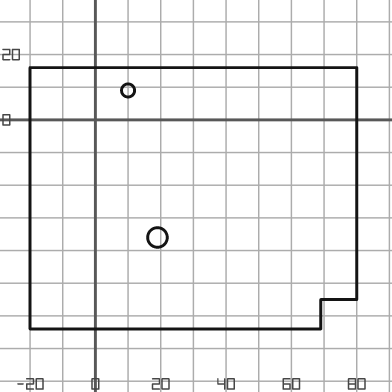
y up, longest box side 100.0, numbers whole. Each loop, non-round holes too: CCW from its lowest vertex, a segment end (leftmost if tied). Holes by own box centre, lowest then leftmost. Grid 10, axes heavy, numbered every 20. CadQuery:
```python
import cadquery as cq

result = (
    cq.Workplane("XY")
    .moveTo(-20.0, -64.0)
    .lineTo(69.0, -64.0)
    .lineTo(69.0, -55.0)
    .lineTo(80.0, -55.0)
    .lineTo(80.0, 16.0)
    .lineTo(-20.0, 16.0)
    .close()
    .moveTo(19.0, -36.0)
    .circle(3.0)
    .moveTo(10.0, 9.0)
    .circle(2.0)
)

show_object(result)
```